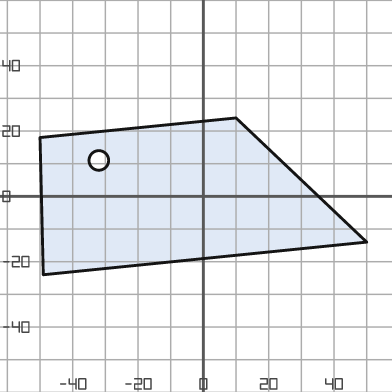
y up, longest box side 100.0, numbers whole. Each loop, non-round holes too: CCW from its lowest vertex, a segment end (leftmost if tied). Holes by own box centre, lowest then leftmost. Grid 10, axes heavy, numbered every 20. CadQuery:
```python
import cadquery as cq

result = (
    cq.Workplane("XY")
    .moveTo(-49.0, -24.0)
    .lineTo(50.0, -14.0)
    .lineTo(10.0, 24.0)
    .lineTo(-50.0, 18.0)
    .close()
    .moveTo(-32.0, 11.0)
    .circle(3.0)
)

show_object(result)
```